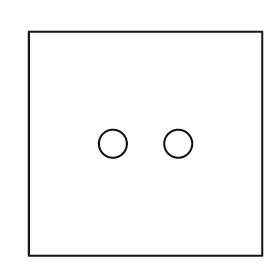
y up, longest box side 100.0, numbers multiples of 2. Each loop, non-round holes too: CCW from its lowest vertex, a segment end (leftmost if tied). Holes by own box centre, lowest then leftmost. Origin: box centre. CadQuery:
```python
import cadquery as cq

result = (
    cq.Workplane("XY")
    .moveTo(-50.0, -48.0)
    .lineTo(50.0, -48.0)
    .lineTo(50.0, 48.0)
    .lineTo(-50.0, 48.0)
    .close()
    .moveTo(-14.0, 0.0)
    .circle(6.0)
    .moveTo(14.0, 0.0)
    .circle(6.0)
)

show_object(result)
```